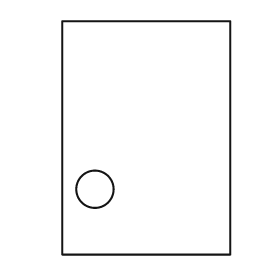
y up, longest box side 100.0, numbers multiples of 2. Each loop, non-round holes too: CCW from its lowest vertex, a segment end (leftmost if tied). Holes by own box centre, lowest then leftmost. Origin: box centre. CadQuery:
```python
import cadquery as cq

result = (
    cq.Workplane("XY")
    .moveTo(-36.0, -50.0)
    .lineTo(36.0, -50.0)
    .lineTo(36.0, 50.0)
    .lineTo(-36.0, 50.0)
    .close()
    .moveTo(-22.0, -22.0)
    .circle(8.0)
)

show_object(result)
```